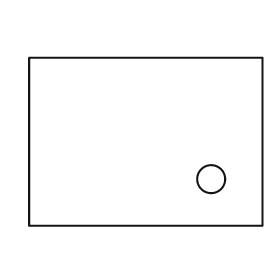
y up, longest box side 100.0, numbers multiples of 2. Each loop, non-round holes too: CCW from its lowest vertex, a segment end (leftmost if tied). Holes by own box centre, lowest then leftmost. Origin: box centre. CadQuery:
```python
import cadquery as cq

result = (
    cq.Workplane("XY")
    .moveTo(-50.0, -36.0)
    .lineTo(50.0, -36.0)
    .lineTo(50.0, 36.0)
    .lineTo(-50.0, 36.0)
    .close()
    .moveTo(28.0, -16.0)
    .circle(6.0)
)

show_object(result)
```